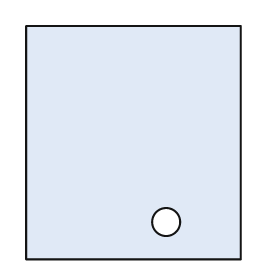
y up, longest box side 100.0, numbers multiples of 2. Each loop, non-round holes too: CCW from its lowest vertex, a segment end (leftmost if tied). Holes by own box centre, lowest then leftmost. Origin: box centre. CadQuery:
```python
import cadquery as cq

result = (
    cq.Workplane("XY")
    .moveTo(-46.0, -50.0)
    .lineTo(46.0, -50.0)
    .lineTo(46.0, 50.0)
    .lineTo(-46.0, 50.0)
    .close()
    .moveTo(14.0, -34.0)
    .circle(6.0)
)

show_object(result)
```